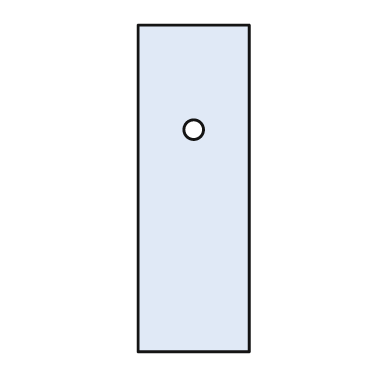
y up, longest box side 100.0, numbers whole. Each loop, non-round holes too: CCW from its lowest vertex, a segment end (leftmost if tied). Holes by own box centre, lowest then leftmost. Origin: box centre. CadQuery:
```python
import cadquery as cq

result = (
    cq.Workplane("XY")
    .moveTo(-17.0, -50.0)
    .lineTo(17.0, -50.0)
    .lineTo(17.0, 50.0)
    .lineTo(-17.0, 50.0)
    .close()
    .moveTo(0.0, 18.0)
    .circle(3.0)
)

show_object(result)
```